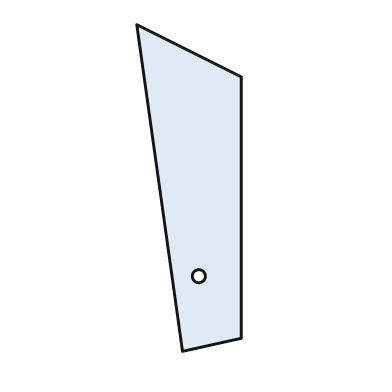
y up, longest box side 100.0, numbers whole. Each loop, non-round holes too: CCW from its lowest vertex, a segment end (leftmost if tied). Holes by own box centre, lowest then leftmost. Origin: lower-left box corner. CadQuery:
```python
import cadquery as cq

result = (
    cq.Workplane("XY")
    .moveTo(14.0, 0.0)
    .lineTo(32.0, 4.0)
    .lineTo(32.0, 84.0)
    .lineTo(0.0, 100.0)
    .close()
    .moveTo(19.0, 23.0)
    .circle(2.0)
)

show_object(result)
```